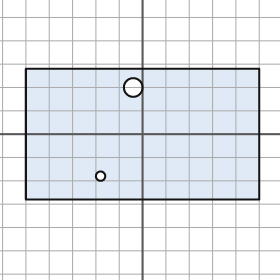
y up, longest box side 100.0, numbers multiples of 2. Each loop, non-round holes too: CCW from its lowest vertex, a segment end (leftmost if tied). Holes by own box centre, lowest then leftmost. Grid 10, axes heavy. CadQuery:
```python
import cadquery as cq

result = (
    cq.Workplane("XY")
    .moveTo(-50.0, -28.0)
    .lineTo(50.0, -28.0)
    .lineTo(50.0, 28.0)
    .lineTo(-50.0, 28.0)
    .close()
    .moveTo(-18.0, -18.0)
    .circle(2.0)
    .moveTo(-4.0, 20.0)
    .circle(4.0)
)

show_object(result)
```